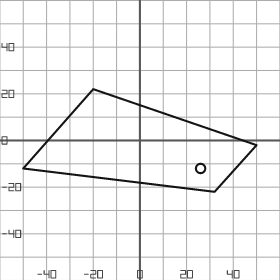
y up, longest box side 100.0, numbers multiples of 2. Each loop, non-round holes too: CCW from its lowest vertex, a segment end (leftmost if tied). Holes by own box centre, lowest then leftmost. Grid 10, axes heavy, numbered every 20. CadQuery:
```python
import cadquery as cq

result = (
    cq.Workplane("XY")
    .moveTo(32.0, -22.0)
    .lineTo(50.0, -2.0)
    .lineTo(-20.0, 22.0)
    .lineTo(-50.0, -12.0)
    .close()
    .moveTo(26.0, -12.0)
    .circle(2.0)
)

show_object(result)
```